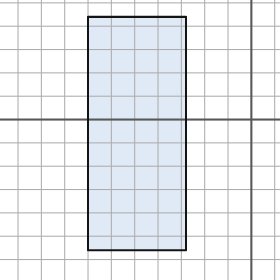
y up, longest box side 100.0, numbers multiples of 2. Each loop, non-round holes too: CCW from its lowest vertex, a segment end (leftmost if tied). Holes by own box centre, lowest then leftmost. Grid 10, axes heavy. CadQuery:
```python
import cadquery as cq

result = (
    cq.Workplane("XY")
    .moveTo(-70.0, -56.0)
    .lineTo(-28.0, -56.0)
    .lineTo(-28.0, 44.0)
    .lineTo(-70.0, 44.0)
    .close()
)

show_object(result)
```